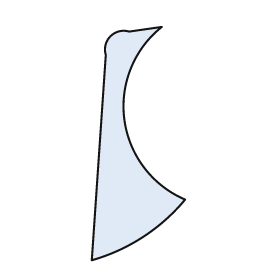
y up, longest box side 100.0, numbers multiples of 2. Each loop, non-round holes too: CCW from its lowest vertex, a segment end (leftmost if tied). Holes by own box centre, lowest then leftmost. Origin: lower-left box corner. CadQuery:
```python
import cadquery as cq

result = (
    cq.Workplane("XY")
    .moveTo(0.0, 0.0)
    .threePointArc((22.0, 10.0), (40.0, 26.0))
    .threePointArc((14.0, 60.0), (30.0, 100.0))
    .lineTo(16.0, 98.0)
    .threePointArc((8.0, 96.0), (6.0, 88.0))
    .close()
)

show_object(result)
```